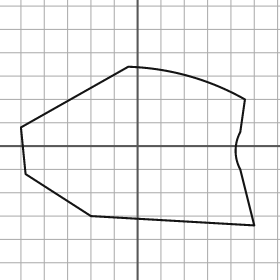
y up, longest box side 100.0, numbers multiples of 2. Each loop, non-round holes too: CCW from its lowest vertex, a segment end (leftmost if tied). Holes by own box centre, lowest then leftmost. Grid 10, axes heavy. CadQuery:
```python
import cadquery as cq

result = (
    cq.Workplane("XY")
    .moveTo(50.0, -34.0)
    .lineTo(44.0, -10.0)
    .threePointArc((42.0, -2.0), (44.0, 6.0))
    .lineTo(46.0, 20.0)
    .threePointArc((22.0, 30.0), (-4.0, 34.0))
    .lineTo(-50.0, 8.0)
    .lineTo(-48.0, -12.0)
    .lineTo(-20.0, -30.0)
    .close()
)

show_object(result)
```